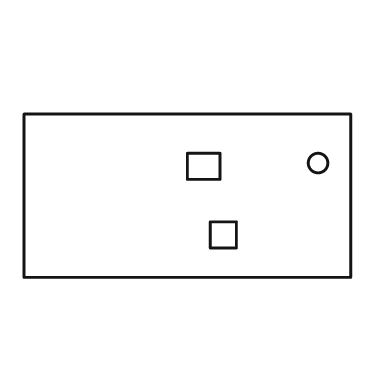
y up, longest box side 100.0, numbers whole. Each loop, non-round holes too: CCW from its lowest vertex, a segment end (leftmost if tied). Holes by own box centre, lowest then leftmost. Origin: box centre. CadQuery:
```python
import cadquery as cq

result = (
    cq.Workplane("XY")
    .moveTo(-50.0, -25.0)
    .lineTo(50.0, -25.0)
    .lineTo(50.0, 25.0)
    .lineTo(-50.0, 25.0)
    .close()
    .moveTo(7.0, -16.0)
    .lineTo(15.0, -16.0)
    .lineTo(15.0, -8.0)
    .lineTo(7.0, -8.0)
    .close()
    .moveTo(0.0, 5.0)
    .lineTo(10.0, 5.0)
    .lineTo(10.0, 13.0)
    .lineTo(0.0, 13.0)
    .close()
    .moveTo(40.0, 10.0)
    .circle(3.0)
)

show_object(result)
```